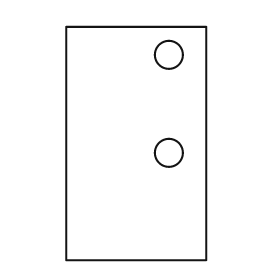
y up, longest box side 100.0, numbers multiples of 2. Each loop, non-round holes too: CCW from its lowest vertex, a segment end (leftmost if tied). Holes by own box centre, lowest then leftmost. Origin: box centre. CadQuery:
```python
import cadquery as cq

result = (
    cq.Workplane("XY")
    .moveTo(-30.0, -50.0)
    .lineTo(30.0, -50.0)
    .lineTo(30.0, 50.0)
    .lineTo(-30.0, 50.0)
    .close()
    .moveTo(14.0, -4.0)
    .circle(6.0)
    .moveTo(14.0, 38.0)
    .circle(6.0)
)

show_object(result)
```